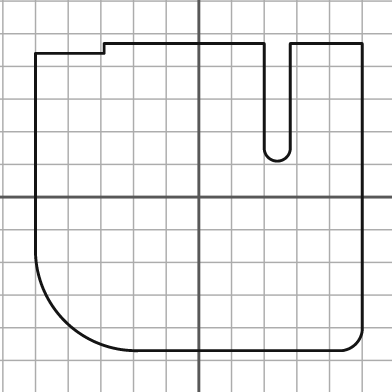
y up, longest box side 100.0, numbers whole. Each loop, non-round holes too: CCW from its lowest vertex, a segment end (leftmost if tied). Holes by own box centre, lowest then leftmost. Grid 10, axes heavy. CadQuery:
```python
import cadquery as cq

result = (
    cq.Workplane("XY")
    .moveTo(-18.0, -47.0)
    .lineTo(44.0, -47.0)
    .threePointArc((48.0, -45.0), (50.0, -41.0))
    .lineTo(50.0, 47.0)
    .lineTo(28.0, 47.0)
    .lineTo(28.0, 15.0)
    .threePointArc((24.0, 11.0), (20.0, 15.0))
    .lineTo(20.0, 47.0)
    .lineTo(-29.0, 47.0)
    .lineTo(-29.0, 44.0)
    .lineTo(-50.0, 44.0)
    .lineTo(-50.0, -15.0)
    .threePointArc((-41.0, -38.0), (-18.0, -47.0))
    .close()
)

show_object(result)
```